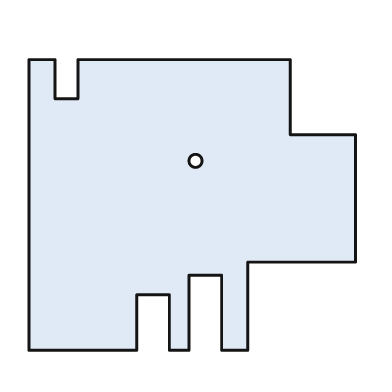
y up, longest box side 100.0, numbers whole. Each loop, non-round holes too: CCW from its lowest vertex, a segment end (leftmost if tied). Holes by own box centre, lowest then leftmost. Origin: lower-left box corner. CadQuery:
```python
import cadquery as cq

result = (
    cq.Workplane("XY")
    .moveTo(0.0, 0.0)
    .lineTo(33.0, 0.0)
    .lineTo(33.0, 17.0)
    .lineTo(43.0, 17.0)
    .lineTo(43.0, 0.0)
    .lineTo(49.0, 0.0)
    .lineTo(49.0, 23.0)
    .lineTo(59.0, 23.0)
    .lineTo(59.0, 0.0)
    .lineTo(67.0, 0.0)
    .lineTo(67.0, 27.0)
    .lineTo(100.0, 27.0)
    .lineTo(100.0, 66.0)
    .lineTo(80.0, 66.0)
    .lineTo(80.0, 89.0)
    .lineTo(15.0, 89.0)
    .lineTo(15.0, 77.0)
    .lineTo(8.0, 77.0)
    .lineTo(8.0, 89.0)
    .lineTo(0.0, 89.0)
    .close()
    .moveTo(51.0, 58.0)
    .circle(2.0)
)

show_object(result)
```